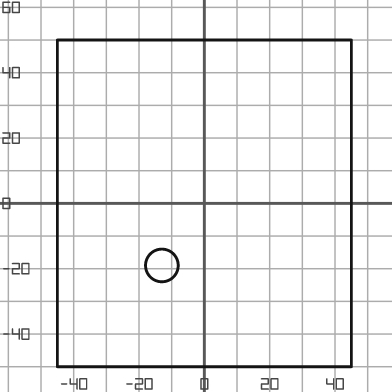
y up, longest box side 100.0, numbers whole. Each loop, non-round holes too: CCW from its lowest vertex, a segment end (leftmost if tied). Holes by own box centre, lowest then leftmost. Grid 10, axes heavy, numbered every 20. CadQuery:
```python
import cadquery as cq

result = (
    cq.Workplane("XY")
    .moveTo(-45.0, -50.0)
    .lineTo(45.0, -50.0)
    .lineTo(45.0, 50.0)
    .lineTo(-45.0, 50.0)
    .close()
    .moveTo(-13.0, -19.0)
    .circle(5.0)
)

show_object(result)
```